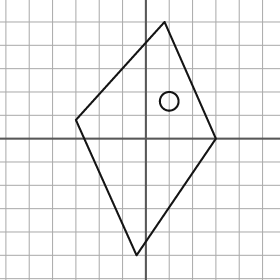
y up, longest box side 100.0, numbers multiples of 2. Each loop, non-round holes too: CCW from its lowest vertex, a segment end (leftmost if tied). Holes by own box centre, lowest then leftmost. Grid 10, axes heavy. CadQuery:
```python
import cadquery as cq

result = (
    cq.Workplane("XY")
    .moveTo(-4.0, -50.0)
    .lineTo(30.0, 0.0)
    .lineTo(8.0, 50.0)
    .lineTo(-30.0, 8.0)
    .close()
    .moveTo(10.0, 16.0)
    .circle(4.0)
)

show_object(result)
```